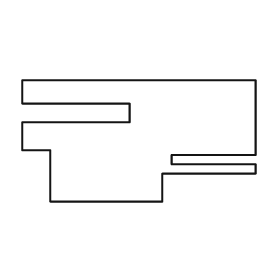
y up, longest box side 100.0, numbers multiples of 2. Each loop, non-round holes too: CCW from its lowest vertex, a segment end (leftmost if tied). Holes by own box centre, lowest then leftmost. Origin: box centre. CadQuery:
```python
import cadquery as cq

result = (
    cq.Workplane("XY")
    .moveTo(-38.0, -26.0)
    .lineTo(10.0, -26.0)
    .lineTo(10.0, -14.0)
    .lineTo(50.0, -14.0)
    .lineTo(50.0, -10.0)
    .lineTo(14.0, -10.0)
    .lineTo(14.0, -6.0)
    .lineTo(50.0, -6.0)
    .lineTo(50.0, 26.0)
    .lineTo(-50.0, 26.0)
    .lineTo(-50.0, 16.0)
    .lineTo(-4.0, 16.0)
    .lineTo(-4.0, 8.0)
    .lineTo(-50.0, 8.0)
    .lineTo(-50.0, -4.0)
    .lineTo(-38.0, -4.0)
    .close()
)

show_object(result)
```